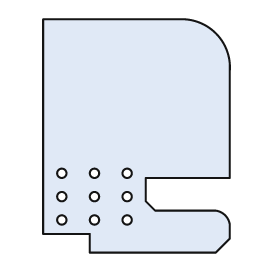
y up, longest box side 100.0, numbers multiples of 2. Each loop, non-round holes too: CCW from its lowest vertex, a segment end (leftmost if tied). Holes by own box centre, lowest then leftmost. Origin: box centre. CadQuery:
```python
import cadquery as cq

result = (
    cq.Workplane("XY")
    .moveTo(-20.0, -50.0)
    .lineTo(34.0, -50.0)
    .lineTo(40.0, -44.0)
    .lineTo(40.0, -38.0)
    .threePointArc((38.0, -34.0), (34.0, -32.0))
    .lineTo(8.0, -32.0)
    .lineTo(4.0, -28.0)
    .lineTo(4.0, -18.0)
    .lineTo(40.0, -18.0)
    .lineTo(40.0, 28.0)
    .threePointArc((34.0, 44.0), (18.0, 50.0))
    .lineTo(-40.0, 50.0)
    .lineTo(-40.0, -42.0)
    .lineTo(-20.0, -42.0)
    .close()
    .moveTo(-32.0, -36.0)
    .circle(2.0)
    .moveTo(-18.0, -36.0)
    .circle(2.0)
    .moveTo(-4.0, -36.0)
    .circle(2.0)
    .moveTo(-32.0, -26.0)
    .circle(2.0)
    .moveTo(-18.0, -26.0)
    .circle(2.0)
    .moveTo(-4.0, -26.0)
    .circle(2.0)
    .moveTo(-32.0, -16.0)
    .circle(2.0)
    .moveTo(-18.0, -16.0)
    .circle(2.0)
    .moveTo(-4.0, -16.0)
    .circle(2.0)
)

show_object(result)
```